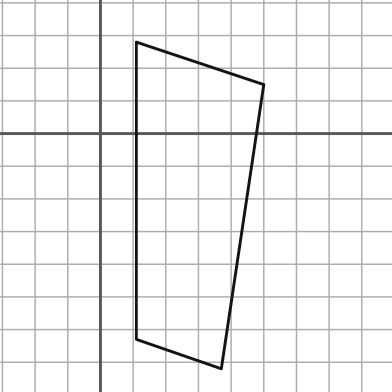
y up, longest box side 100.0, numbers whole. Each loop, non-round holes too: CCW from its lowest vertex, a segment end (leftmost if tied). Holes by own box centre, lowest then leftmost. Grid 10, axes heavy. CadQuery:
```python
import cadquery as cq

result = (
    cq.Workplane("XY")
    .moveTo(37.0, -72.0)
    .lineTo(50.0, 15.0)
    .lineTo(11.0, 28.0)
    .lineTo(11.0, -63.0)
    .close()
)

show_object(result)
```